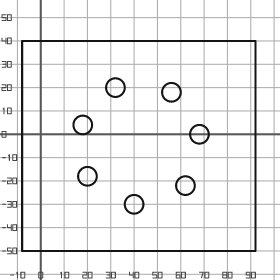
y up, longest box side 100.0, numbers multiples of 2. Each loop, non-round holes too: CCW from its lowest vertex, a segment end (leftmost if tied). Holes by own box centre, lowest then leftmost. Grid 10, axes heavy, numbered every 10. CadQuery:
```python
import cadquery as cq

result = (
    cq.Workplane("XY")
    .moveTo(-8.0, -50.0)
    .lineTo(92.0, -50.0)
    .lineTo(92.0, 40.0)
    .lineTo(-8.0, 40.0)
    .close()
    .moveTo(40.0, -30.0)
    .circle(4.0)
    .moveTo(62.0, -22.0)
    .circle(4.0)
    .moveTo(20.0, -18.0)
    .circle(4.0)
    .moveTo(68.0, 0.0)
    .circle(4.0)
    .moveTo(18.0, 4.0)
    .circle(4.0)
    .moveTo(56.0, 18.0)
    .circle(4.0)
    .moveTo(32.0, 20.0)
    .circle(4.0)
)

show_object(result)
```